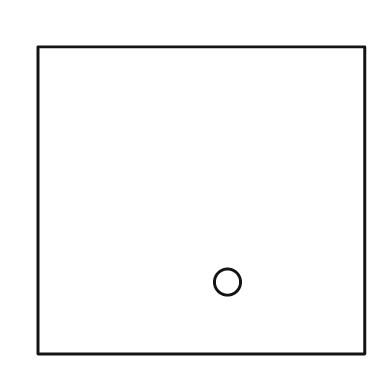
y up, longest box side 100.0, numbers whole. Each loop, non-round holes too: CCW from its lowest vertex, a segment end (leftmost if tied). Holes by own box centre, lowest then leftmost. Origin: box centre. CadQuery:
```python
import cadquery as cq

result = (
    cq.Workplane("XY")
    .moveTo(-50.0, -47.0)
    .lineTo(50.0, -47.0)
    .lineTo(50.0, 47.0)
    .lineTo(-50.0, 47.0)
    .close()
    .moveTo(8.0, -25.0)
    .circle(4.0)
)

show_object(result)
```